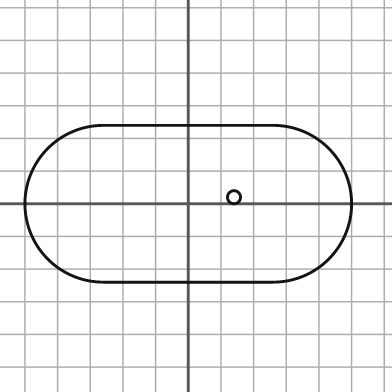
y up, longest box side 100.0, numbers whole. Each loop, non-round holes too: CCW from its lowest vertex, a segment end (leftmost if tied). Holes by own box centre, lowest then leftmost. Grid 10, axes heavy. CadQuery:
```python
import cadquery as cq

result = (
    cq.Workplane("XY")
    .moveTo(-26.0, -24.0)
    .lineTo(26.0, -24.0)
    .threePointArc((50.0, 0.0), (26.0, 24.0))
    .lineTo(-26.0, 24.0)
    .threePointArc((-50.0, 0.0), (-26.0, -24.0))
    .close()
    .moveTo(14.0, 2.0)
    .circle(2.0)
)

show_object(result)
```